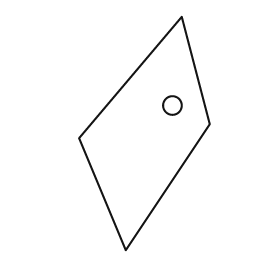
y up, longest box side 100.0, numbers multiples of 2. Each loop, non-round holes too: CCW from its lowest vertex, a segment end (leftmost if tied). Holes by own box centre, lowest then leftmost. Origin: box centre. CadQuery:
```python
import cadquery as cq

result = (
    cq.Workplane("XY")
    .moveTo(-8.0, -50.0)
    .lineTo(28.0, 4.0)
    .lineTo(16.0, 50.0)
    .lineTo(-28.0, -2.0)
    .close()
    .moveTo(12.0, 12.0)
    .circle(4.0)
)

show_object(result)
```